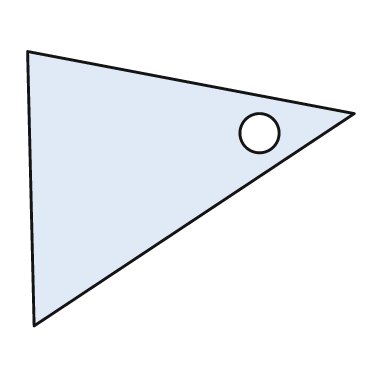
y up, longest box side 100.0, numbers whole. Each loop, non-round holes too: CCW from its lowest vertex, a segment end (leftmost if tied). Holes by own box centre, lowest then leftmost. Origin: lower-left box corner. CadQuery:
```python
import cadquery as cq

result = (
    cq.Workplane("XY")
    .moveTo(2.0, 0.0)
    .lineTo(100.0, 65.0)
    .lineTo(0.0, 84.0)
    .close()
    .moveTo(71.0, 59.0)
    .circle(6.0)
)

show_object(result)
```